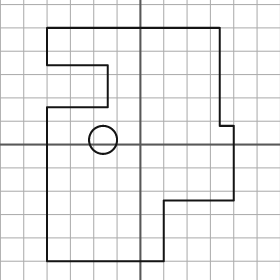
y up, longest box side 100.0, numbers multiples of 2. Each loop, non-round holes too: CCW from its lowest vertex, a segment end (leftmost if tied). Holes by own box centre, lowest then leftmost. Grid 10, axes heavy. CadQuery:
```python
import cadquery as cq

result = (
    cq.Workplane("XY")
    .moveTo(-40.0, -50.0)
    .lineTo(10.0, -50.0)
    .lineTo(10.0, -24.0)
    .lineTo(40.0, -24.0)
    .lineTo(40.0, 8.0)
    .lineTo(34.0, 8.0)
    .lineTo(34.0, 50.0)
    .lineTo(-40.0, 50.0)
    .lineTo(-40.0, 34.0)
    .lineTo(-14.0, 34.0)
    .lineTo(-14.0, 16.0)
    .lineTo(-40.0, 16.0)
    .close()
    .moveTo(-16.0, 2.0)
    .circle(6.0)
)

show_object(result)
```